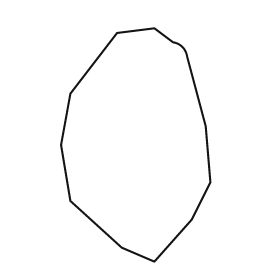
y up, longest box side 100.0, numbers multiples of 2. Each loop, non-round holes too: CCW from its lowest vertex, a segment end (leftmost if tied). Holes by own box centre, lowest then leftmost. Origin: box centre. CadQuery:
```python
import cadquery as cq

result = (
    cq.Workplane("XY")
    .moveTo(8.0, -50.0)
    .lineTo(24.0, -32.0)
    .lineTo(32.0, -16.0)
    .lineTo(30.0, 8.0)
    .lineTo(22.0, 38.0)
    .threePointArc((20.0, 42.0), (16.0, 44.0))
    .lineTo(8.0, 50.0)
    .lineTo(-8.0, 48.0)
    .lineTo(-28.0, 22.0)
    .lineTo(-32.0, 0.0)
    .lineTo(-28.0, -24.0)
    .lineTo(-6.0, -44.0)
    .close()
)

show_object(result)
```